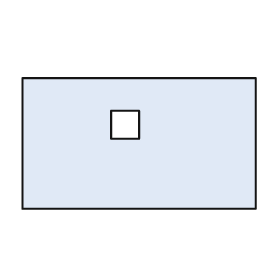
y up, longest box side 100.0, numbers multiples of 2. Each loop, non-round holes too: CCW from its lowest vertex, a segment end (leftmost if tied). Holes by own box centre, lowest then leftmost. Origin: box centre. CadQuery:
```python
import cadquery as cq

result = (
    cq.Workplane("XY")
    .moveTo(-50.0, -28.0)
    .lineTo(50.0, -28.0)
    .lineTo(50.0, 28.0)
    .lineTo(-50.0, 28.0)
    .close()
    .moveTo(-12.0, 2.0)
    .lineTo(0.0, 2.0)
    .lineTo(0.0, 14.0)
    .lineTo(-12.0, 14.0)
    .close()
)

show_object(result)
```